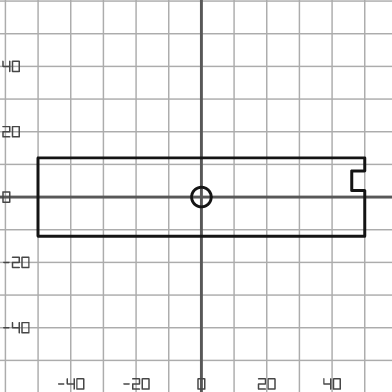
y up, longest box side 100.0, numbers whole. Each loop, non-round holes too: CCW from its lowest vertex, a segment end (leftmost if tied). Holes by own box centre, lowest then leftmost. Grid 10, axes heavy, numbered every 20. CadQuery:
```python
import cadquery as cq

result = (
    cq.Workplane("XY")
    .moveTo(-50.0, -12.0)
    .lineTo(50.0, -12.0)
    .lineTo(50.0, 2.0)
    .lineTo(46.0, 2.0)
    .lineTo(46.0, 8.0)
    .lineTo(50.0, 8.0)
    .lineTo(50.0, 12.0)
    .lineTo(-50.0, 12.0)
    .close()
    .moveTo(0.0, 0.0)
    .circle(3.0)
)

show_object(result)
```